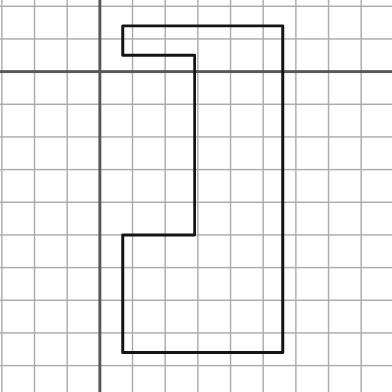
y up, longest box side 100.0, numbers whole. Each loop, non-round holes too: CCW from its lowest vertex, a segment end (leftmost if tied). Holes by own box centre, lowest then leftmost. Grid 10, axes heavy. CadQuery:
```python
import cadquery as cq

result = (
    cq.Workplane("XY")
    .moveTo(7.0, -86.0)
    .lineTo(56.0, -86.0)
    .lineTo(56.0, 14.0)
    .lineTo(7.0, 14.0)
    .lineTo(7.0, 5.0)
    .lineTo(29.0, 5.0)
    .lineTo(29.0, -50.0)
    .lineTo(7.0, -50.0)
    .close()
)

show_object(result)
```